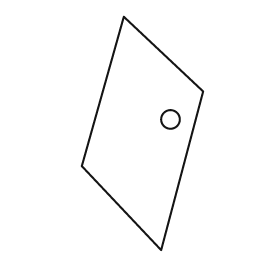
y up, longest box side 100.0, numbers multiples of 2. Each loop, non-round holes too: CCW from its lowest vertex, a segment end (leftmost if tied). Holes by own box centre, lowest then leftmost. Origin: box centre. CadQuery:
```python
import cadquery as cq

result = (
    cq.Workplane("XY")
    .moveTo(8.0, -50.0)
    .lineTo(26.0, 18.0)
    .lineTo(-8.0, 50.0)
    .lineTo(-26.0, -14.0)
    .close()
    .moveTo(12.0, 6.0)
    .circle(4.0)
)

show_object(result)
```